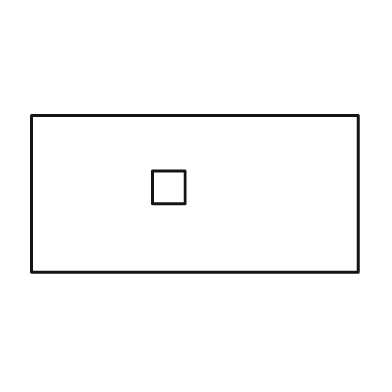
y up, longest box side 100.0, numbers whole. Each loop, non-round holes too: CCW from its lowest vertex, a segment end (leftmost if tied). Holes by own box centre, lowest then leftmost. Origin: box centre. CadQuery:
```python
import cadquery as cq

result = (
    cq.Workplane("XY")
    .moveTo(-50.0, -24.0)
    .lineTo(50.0, -24.0)
    .lineTo(50.0, 24.0)
    .lineTo(-50.0, 24.0)
    .close()
    .moveTo(-13.0, -3.0)
    .lineTo(-3.0, -3.0)
    .lineTo(-3.0, 7.0)
    .lineTo(-13.0, 7.0)
    .close()
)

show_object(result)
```